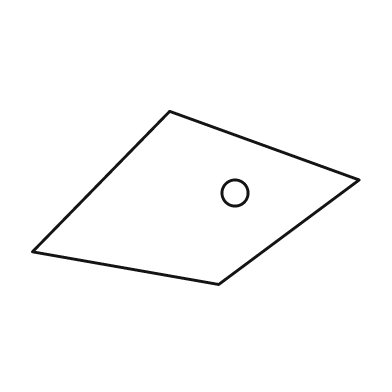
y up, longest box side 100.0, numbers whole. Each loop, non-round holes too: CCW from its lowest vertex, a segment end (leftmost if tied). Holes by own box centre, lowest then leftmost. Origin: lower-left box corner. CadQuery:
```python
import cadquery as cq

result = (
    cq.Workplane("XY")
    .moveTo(57.0, 0.0)
    .lineTo(100.0, 32.0)
    .lineTo(42.0, 53.0)
    .lineTo(0.0, 10.0)
    .close()
    .moveTo(62.0, 28.0)
    .circle(4.0)
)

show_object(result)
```